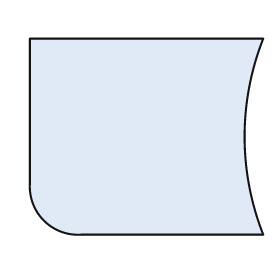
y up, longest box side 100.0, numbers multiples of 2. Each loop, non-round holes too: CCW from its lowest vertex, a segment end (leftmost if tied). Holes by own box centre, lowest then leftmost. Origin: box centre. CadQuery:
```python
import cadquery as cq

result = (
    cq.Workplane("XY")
    .moveTo(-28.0, -42.0)
    .lineTo(50.0, -42.0)
    .threePointArc((42.0, 0.0), (50.0, 42.0))
    .lineTo(-50.0, 42.0)
    .lineTo(-50.0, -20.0)
    .threePointArc((-44.0, -36.0), (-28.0, -42.0))
    .close()
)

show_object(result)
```